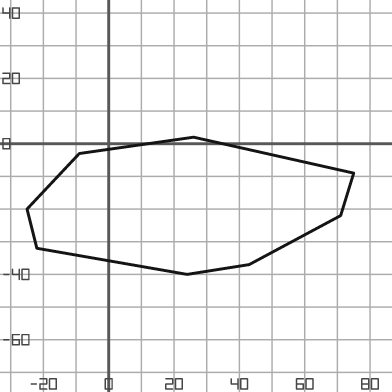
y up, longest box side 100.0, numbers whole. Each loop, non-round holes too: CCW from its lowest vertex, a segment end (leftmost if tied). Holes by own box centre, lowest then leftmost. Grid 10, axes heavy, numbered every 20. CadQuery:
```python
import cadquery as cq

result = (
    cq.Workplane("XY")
    .moveTo(24.0, -40.0)
    .lineTo(43.0, -37.0)
    .lineTo(71.0, -22.0)
    .lineTo(75.0, -9.0)
    .lineTo(26.0, 2.0)
    .lineTo(-9.0, -3.0)
    .lineTo(-25.0, -20.0)
    .lineTo(-22.0, -32.0)
    .close()
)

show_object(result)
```